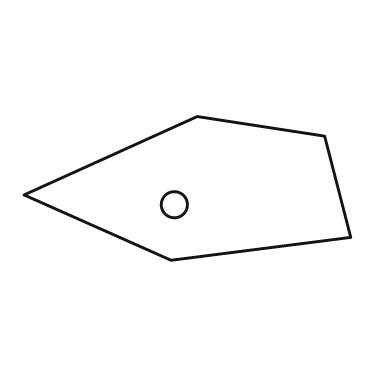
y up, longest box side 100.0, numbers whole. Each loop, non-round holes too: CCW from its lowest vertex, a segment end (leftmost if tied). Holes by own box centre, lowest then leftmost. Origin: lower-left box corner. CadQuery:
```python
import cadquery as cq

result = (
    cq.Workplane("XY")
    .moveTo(45.0, 0.0)
    .lineTo(100.0, 7.0)
    .lineTo(92.0, 38.0)
    .lineTo(53.0, 44.0)
    .lineTo(0.0, 20.0)
    .close()
    .moveTo(46.0, 17.0)
    .circle(4.0)
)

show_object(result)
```